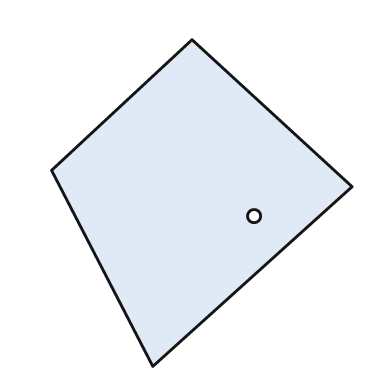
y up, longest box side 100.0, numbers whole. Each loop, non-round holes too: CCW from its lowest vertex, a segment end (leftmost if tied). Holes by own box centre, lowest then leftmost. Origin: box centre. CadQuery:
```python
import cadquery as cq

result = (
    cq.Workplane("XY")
    .moveTo(-15.0, -50.0)
    .lineTo(46.0, 5.0)
    .lineTo(-3.0, 50.0)
    .lineTo(-46.0, 10.0)
    .close()
    .moveTo(16.0, -4.0)
    .circle(2.0)
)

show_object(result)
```